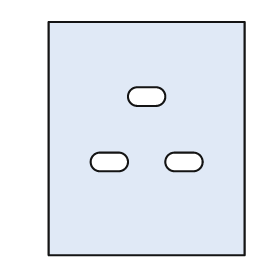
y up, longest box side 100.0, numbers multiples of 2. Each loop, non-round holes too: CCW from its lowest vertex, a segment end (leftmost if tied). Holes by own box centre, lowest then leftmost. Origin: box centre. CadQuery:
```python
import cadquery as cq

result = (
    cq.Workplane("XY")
    .moveTo(-42.0, -50.0)
    .lineTo(42.0, -50.0)
    .lineTo(42.0, 50.0)
    .lineTo(-42.0, 50.0)
    .close()
    .moveTo(-20.0, -14.0)
    .lineTo(-12.0, -14.0)
    .threePointArc((-8.0, -10.0), (-12.0, -6.0))
    .lineTo(-20.0, -6.0)
    .threePointArc((-24.0, -10.0), (-20.0, -14.0))
    .close()
    .moveTo(12.0, -14.0)
    .lineTo(20.0, -14.0)
    .threePointArc((24.0, -10.0), (20.0, -6.0))
    .lineTo(12.0, -6.0)
    .threePointArc((8.0, -10.0), (12.0, -14.0))
    .close()
    .moveTo(-4.0, 14.0)
    .lineTo(4.0, 14.0)
    .threePointArc((8.0, 18.0), (4.0, 22.0))
    .lineTo(-4.0, 22.0)
    .threePointArc((-8.0, 18.0), (-4.0, 14.0))
    .close()
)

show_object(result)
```